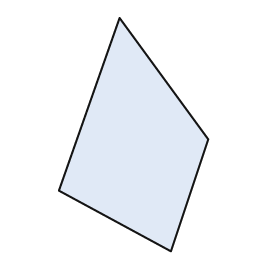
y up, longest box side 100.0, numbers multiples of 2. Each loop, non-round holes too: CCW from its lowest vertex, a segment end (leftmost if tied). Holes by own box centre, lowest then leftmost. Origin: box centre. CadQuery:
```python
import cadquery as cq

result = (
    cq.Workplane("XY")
    .moveTo(16.0, -50.0)
    .lineTo(32.0, -2.0)
    .lineTo(-6.0, 50.0)
    .lineTo(-32.0, -24.0)
    .close()
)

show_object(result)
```